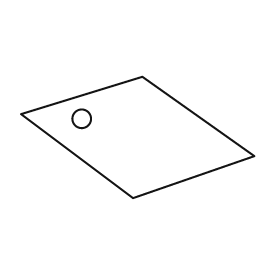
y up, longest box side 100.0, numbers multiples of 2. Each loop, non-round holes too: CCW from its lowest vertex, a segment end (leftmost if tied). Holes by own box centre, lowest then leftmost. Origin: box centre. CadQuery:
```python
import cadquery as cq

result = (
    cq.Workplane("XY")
    .moveTo(-2.0, -26.0)
    .lineTo(50.0, -8.0)
    .lineTo(2.0, 26.0)
    .lineTo(-50.0, 10.0)
    .close()
    .moveTo(-24.0, 8.0)
    .circle(4.0)
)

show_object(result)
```